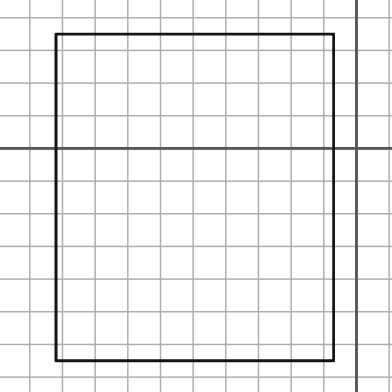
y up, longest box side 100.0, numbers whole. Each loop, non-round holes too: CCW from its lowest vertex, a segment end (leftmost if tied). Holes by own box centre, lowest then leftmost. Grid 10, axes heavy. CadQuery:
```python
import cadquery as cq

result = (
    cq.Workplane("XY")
    .moveTo(-92.0, -65.0)
    .lineTo(-7.0, -65.0)
    .lineTo(-7.0, 35.0)
    .lineTo(-92.0, 35.0)
    .close()
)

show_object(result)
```